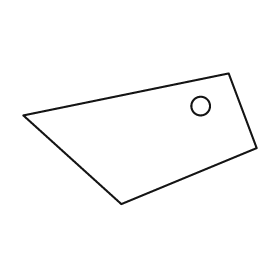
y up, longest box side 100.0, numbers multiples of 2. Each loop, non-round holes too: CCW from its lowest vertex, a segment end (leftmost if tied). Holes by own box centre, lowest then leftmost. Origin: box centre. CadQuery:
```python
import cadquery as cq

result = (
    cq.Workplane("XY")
    .moveTo(-8.0, -28.0)
    .lineTo(50.0, -4.0)
    .lineTo(38.0, 28.0)
    .lineTo(-50.0, 10.0)
    .close()
    .moveTo(26.0, 14.0)
    .circle(4.0)
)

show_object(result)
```